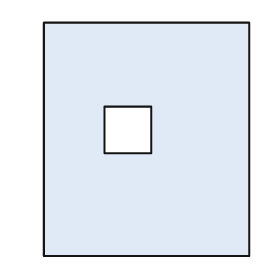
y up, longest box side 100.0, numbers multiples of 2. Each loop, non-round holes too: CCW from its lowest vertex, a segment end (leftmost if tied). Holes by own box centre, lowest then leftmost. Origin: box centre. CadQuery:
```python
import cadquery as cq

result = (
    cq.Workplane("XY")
    .moveTo(-44.0, -50.0)
    .lineTo(44.0, -50.0)
    .lineTo(44.0, 50.0)
    .lineTo(-44.0, 50.0)
    .close()
    .moveTo(-18.0, -6.0)
    .lineTo(2.0, -6.0)
    .lineTo(2.0, 14.0)
    .lineTo(-18.0, 14.0)
    .close()
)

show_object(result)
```